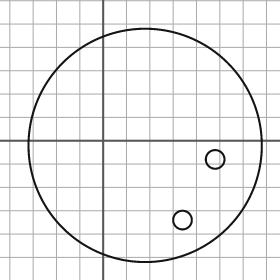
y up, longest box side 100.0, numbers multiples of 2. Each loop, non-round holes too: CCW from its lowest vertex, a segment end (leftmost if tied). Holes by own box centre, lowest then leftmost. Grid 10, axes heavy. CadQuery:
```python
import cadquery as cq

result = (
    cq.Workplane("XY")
    .moveTo(18.0, -2.0)
    .circle(50.0)
    .moveTo(34.0, -34.0)
    .circle(4.0)
    .moveTo(48.0, -8.0)
    .circle(4.0)
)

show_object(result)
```